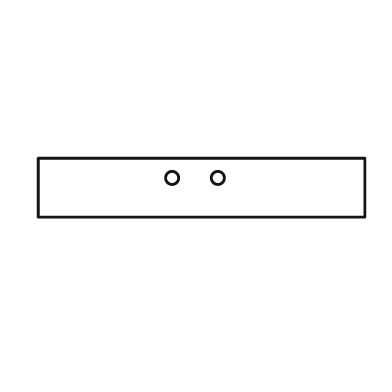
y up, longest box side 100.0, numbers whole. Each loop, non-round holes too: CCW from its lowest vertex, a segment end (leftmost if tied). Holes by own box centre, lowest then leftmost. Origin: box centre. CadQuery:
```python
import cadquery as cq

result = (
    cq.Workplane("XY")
    .moveTo(-50.0, -9.0)
    .lineTo(50.0, -9.0)
    .lineTo(50.0, 9.0)
    .lineTo(-50.0, 9.0)
    .close()
    .moveTo(-9.0, 3.0)
    .circle(2.0)
    .moveTo(5.0, 3.0)
    .circle(2.0)
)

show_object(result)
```